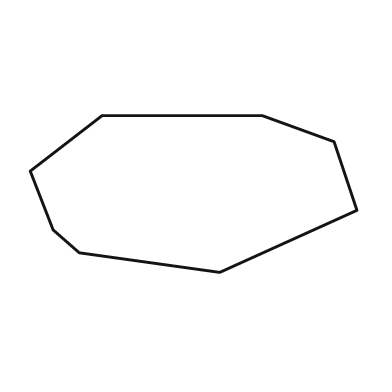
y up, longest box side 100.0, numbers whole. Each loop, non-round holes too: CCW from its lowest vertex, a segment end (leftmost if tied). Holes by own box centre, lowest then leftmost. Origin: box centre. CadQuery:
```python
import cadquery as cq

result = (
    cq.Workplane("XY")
    .moveTo(8.0, -24.0)
    .lineTo(50.0, -5.0)
    .lineTo(43.0, 16.0)
    .lineTo(21.0, 24.0)
    .lineTo(-28.0, 24.0)
    .lineTo(-50.0, 7.0)
    .lineTo(-43.0, -11.0)
    .lineTo(-35.0, -18.0)
    .close()
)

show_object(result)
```